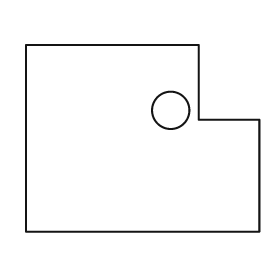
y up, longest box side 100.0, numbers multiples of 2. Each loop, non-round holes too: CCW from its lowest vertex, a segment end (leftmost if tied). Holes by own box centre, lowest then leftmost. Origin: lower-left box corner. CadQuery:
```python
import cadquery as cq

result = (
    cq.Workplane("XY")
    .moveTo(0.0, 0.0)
    .lineTo(100.0, 0.0)
    .lineTo(100.0, 48.0)
    .lineTo(74.0, 48.0)
    .lineTo(74.0, 80.0)
    .lineTo(0.0, 80.0)
    .close()
    .moveTo(62.0, 52.0)
    .circle(8.0)
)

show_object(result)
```